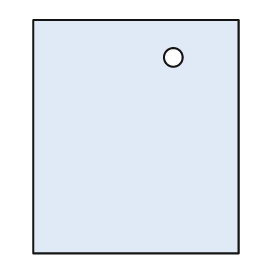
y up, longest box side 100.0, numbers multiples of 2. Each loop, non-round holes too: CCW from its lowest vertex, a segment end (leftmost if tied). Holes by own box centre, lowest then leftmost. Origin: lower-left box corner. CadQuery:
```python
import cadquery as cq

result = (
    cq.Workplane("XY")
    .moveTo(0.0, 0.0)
    .lineTo(88.0, 0.0)
    .lineTo(88.0, 100.0)
    .lineTo(0.0, 100.0)
    .close()
    .moveTo(60.0, 84.0)
    .circle(4.0)
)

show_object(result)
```